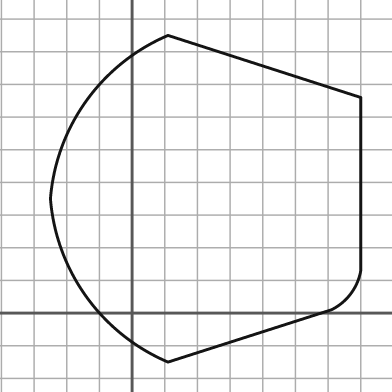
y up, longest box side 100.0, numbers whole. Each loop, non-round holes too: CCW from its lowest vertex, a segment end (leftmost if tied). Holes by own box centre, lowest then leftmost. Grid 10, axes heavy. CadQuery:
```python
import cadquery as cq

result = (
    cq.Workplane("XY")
    .moveTo(11.0, -15.0)
    .lineTo(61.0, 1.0)
    .threePointArc((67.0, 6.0), (70.0, 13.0))
    .lineTo(70.0, 66.0)
    .lineTo(11.0, 85.0)
    .threePointArc((-14.0, 65.0), (-25.0, 35.0))
    .threePointArc((-14.0, 5.0), (11.0, -15.0))
    .close()
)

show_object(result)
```